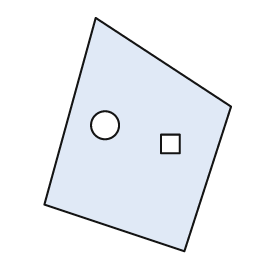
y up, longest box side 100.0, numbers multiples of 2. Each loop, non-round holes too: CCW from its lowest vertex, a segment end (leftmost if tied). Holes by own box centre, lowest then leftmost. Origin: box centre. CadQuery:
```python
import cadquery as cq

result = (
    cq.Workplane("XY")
    .moveTo(20.0, -50.0)
    .lineTo(40.0, 12.0)
    .lineTo(-18.0, 50.0)
    .lineTo(-40.0, -30.0)
    .close()
    .moveTo(10.0, -8.0)
    .lineTo(18.0, -8.0)
    .lineTo(18.0, 0.0)
    .lineTo(10.0, 0.0)
    .close()
    .moveTo(-14.0, 4.0)
    .circle(6.0)
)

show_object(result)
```